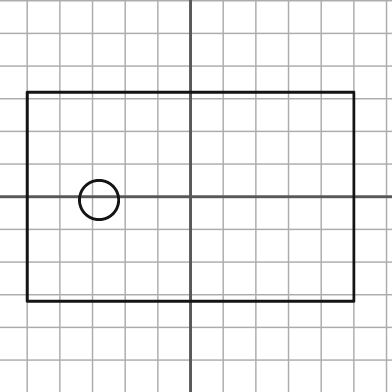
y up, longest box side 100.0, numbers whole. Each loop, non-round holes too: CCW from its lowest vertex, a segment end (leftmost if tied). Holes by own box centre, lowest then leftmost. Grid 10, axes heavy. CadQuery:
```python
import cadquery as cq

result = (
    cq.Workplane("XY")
    .moveTo(-50.0, -32.0)
    .lineTo(50.0, -32.0)
    .lineTo(50.0, 32.0)
    .lineTo(-50.0, 32.0)
    .close()
    .moveTo(-28.0, -1.0)
    .circle(6.0)
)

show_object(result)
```